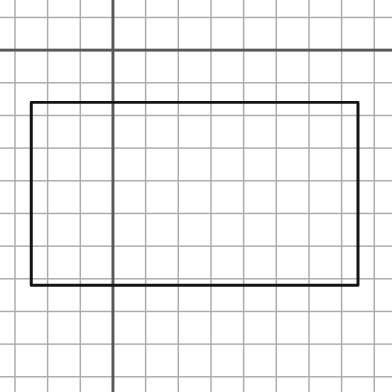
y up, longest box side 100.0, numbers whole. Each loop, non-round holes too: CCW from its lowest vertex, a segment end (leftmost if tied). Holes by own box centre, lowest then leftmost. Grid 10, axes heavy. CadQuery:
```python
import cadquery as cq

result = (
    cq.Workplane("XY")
    .moveTo(-25.0, -72.0)
    .lineTo(75.0, -72.0)
    .lineTo(75.0, -16.0)
    .lineTo(-25.0, -16.0)
    .close()
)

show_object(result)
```